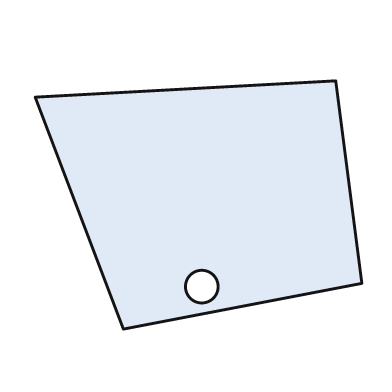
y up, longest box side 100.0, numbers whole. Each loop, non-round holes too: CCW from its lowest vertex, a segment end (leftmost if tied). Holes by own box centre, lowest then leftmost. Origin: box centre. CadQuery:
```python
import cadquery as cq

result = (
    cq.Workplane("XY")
    .moveTo(-23.0, -38.0)
    .lineTo(50.0, -24.0)
    .lineTo(42.0, 38.0)
    .lineTo(-50.0, 33.0)
    .close()
    .moveTo(1.0, -25.0)
    .circle(5.0)
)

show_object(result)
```